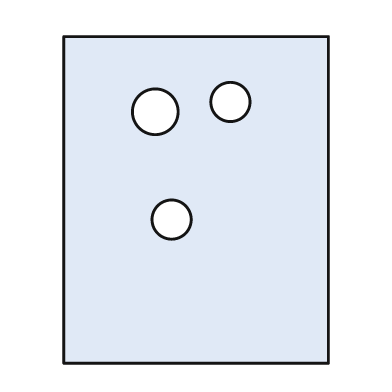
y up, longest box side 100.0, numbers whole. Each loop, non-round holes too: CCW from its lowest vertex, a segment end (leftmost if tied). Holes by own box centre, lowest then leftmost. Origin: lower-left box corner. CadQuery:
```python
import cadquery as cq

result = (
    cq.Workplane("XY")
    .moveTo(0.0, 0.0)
    .lineTo(81.0, 0.0)
    .lineTo(81.0, 100.0)
    .lineTo(0.0, 100.0)
    .close()
    .moveTo(33.0, 44.0)
    .circle(6.0)
    .moveTo(28.0, 77.0)
    .circle(7.0)
    .moveTo(51.0, 80.0)
    .circle(6.0)
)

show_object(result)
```